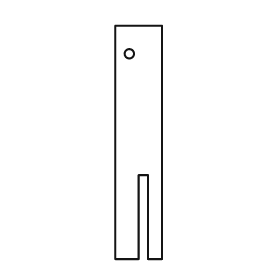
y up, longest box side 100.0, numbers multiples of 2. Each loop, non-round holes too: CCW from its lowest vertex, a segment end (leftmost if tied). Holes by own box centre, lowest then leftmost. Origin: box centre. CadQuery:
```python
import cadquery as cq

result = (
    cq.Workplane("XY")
    .moveTo(-10.0, -50.0)
    .lineTo(0.0, -50.0)
    .lineTo(0.0, -14.0)
    .lineTo(4.0, -14.0)
    .lineTo(4.0, -50.0)
    .lineTo(10.0, -50.0)
    .lineTo(10.0, 50.0)
    .lineTo(-10.0, 50.0)
    .close()
    .moveTo(-4.0, 38.0)
    .circle(2.0)
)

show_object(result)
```